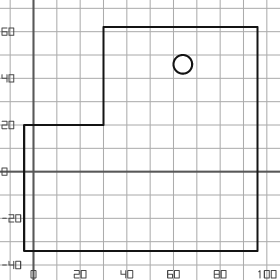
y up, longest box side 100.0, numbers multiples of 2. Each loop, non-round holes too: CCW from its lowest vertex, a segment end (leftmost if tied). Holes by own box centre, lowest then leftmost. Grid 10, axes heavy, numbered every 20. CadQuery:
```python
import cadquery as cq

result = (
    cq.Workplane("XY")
    .moveTo(-4.0, -34.0)
    .lineTo(96.0, -34.0)
    .lineTo(96.0, 62.0)
    .lineTo(30.0, 62.0)
    .lineTo(30.0, 20.0)
    .lineTo(-4.0, 20.0)
    .close()
    .moveTo(64.0, 46.0)
    .circle(4.0)
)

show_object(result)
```